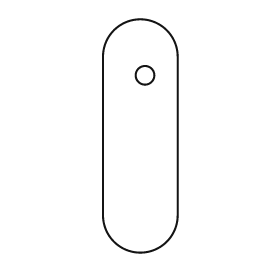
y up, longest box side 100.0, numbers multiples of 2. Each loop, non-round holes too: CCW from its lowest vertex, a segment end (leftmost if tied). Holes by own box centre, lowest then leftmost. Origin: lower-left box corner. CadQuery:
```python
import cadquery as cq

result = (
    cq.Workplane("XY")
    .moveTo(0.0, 16.0)
    .threePointArc((16.0, 0.0), (32.0, 16.0))
    .lineTo(32.0, 84.0)
    .threePointArc((16.0, 100.0), (0.0, 84.0))
    .close()
    .moveTo(18.0, 76.0)
    .circle(4.0)
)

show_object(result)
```